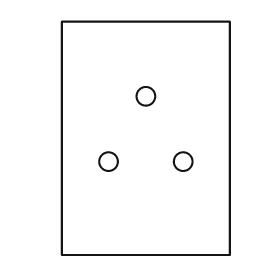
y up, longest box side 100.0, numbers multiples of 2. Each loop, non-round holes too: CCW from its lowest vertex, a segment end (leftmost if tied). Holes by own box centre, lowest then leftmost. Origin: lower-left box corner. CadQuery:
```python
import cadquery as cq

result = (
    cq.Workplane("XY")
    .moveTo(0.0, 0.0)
    .lineTo(72.0, 0.0)
    .lineTo(72.0, 100.0)
    .lineTo(0.0, 100.0)
    .close()
    .moveTo(20.0, 40.0)
    .circle(4.0)
    .moveTo(52.0, 40.0)
    .circle(4.0)
    .moveTo(36.0, 68.0)
    .circle(4.0)
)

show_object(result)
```